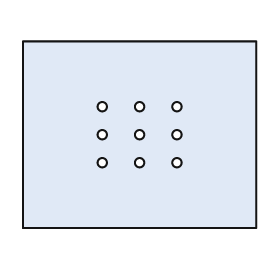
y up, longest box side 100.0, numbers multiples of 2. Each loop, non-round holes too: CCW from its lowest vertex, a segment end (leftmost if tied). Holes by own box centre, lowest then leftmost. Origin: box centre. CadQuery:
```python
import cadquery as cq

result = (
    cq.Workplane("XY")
    .moveTo(-50.0, -40.0)
    .lineTo(50.0, -40.0)
    .lineTo(50.0, 40.0)
    .lineTo(-50.0, 40.0)
    .close()
    .moveTo(-16.0, -12.0)
    .circle(2.0)
    .moveTo(0.0, -12.0)
    .circle(2.0)
    .moveTo(16.0, -12.0)
    .circle(2.0)
    .moveTo(-16.0, 0.0)
    .circle(2.0)
    .moveTo(0.0, 0.0)
    .circle(2.0)
    .moveTo(16.0, 0.0)
    .circle(2.0)
    .moveTo(-16.0, 12.0)
    .circle(2.0)
    .moveTo(0.0, 12.0)
    .circle(2.0)
    .moveTo(16.0, 12.0)
    .circle(2.0)
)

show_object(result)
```